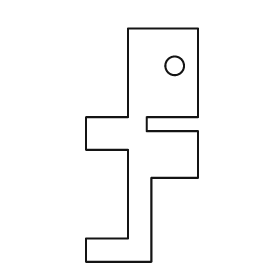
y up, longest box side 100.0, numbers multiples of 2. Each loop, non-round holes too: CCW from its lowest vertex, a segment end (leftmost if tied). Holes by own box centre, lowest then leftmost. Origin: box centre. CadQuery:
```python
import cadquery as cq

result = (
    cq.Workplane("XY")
    .moveTo(-24.0, -50.0)
    .lineTo(4.0, -50.0)
    .lineTo(4.0, -14.0)
    .lineTo(24.0, -14.0)
    .lineTo(24.0, 6.0)
    .lineTo(2.0, 6.0)
    .lineTo(2.0, 12.0)
    .lineTo(24.0, 12.0)
    .lineTo(24.0, 50.0)
    .lineTo(-6.0, 50.0)
    .lineTo(-6.0, 12.0)
    .lineTo(-24.0, 12.0)
    .lineTo(-24.0, -2.0)
    .lineTo(-6.0, -2.0)
    .lineTo(-6.0, -40.0)
    .lineTo(-24.0, -40.0)
    .close()
    .moveTo(14.0, 34.0)
    .circle(4.0)
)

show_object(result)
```